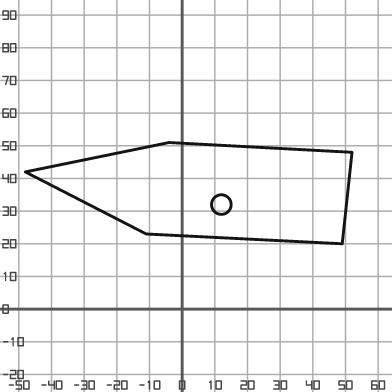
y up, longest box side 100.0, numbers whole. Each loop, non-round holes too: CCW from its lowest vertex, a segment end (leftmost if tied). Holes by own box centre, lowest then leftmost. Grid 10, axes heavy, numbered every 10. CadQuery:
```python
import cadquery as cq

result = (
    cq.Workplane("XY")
    .moveTo(49.0, 20.0)
    .lineTo(52.0, 48.0)
    .lineTo(-4.0, 51.0)
    .lineTo(-48.0, 42.0)
    .lineTo(-11.0, 23.0)
    .close()
    .moveTo(12.0, 32.0)
    .circle(3.0)
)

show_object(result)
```